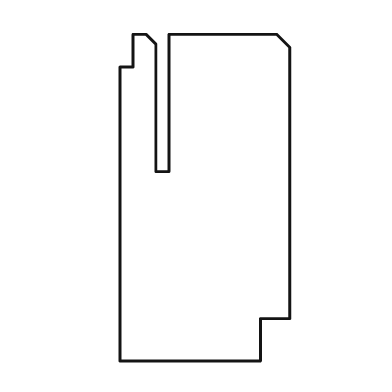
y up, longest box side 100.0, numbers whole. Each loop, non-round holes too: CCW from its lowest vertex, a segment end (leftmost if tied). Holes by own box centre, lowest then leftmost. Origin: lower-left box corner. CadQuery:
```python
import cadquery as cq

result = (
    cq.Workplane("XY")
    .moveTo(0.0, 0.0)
    .lineTo(43.0, 0.0)
    .lineTo(43.0, 13.0)
    .lineTo(52.0, 13.0)
    .lineTo(52.0, 96.0)
    .lineTo(48.0, 100.0)
    .lineTo(15.0, 100.0)
    .lineTo(15.0, 58.0)
    .lineTo(11.0, 58.0)
    .lineTo(11.0, 97.0)
    .lineTo(8.0, 100.0)
    .lineTo(4.0, 100.0)
    .lineTo(4.0, 90.0)
    .lineTo(0.0, 90.0)
    .close()
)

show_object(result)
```